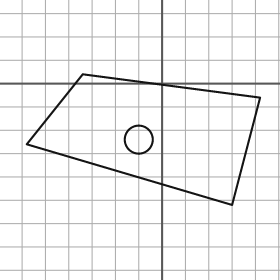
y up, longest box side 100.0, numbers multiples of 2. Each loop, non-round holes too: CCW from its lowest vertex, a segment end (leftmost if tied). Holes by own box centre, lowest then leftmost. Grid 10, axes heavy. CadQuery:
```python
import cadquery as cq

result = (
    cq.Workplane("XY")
    .moveTo(30.0, -52.0)
    .lineTo(42.0, -6.0)
    .lineTo(-34.0, 4.0)
    .lineTo(-58.0, -26.0)
    .close()
    .moveTo(-10.0, -24.0)
    .circle(6.0)
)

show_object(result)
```